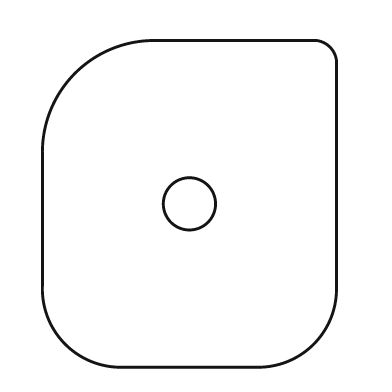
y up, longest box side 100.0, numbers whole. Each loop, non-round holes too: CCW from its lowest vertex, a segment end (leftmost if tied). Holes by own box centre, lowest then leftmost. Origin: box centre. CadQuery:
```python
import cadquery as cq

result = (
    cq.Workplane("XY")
    .moveTo(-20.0, -50.0)
    .lineTo(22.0, -50.0)
    .threePointArc((38.0, -43.0), (45.0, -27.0))
    .lineTo(45.0, 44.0)
    .threePointArc((43.0, 48.0), (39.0, 50.0))
    .lineTo(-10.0, 50.0)
    .threePointArc((-35.0, 40.0), (-45.0, 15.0))
    .lineTo(-45.0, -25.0)
    .threePointArc((-38.0, -43.0), (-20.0, -50.0))
    .close()
    .moveTo(0.0, 0.0)
    .circle(8.0)
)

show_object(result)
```